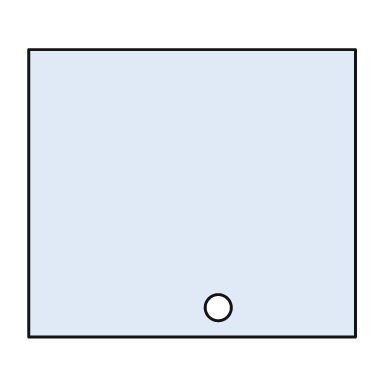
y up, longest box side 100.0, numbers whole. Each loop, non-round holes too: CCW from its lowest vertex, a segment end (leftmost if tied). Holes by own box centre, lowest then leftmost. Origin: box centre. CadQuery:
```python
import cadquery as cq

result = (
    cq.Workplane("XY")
    .moveTo(-50.0, -44.0)
    .lineTo(50.0, -44.0)
    .lineTo(50.0, 44.0)
    .lineTo(-50.0, 44.0)
    .close()
    .moveTo(8.0, -35.0)
    .circle(4.0)
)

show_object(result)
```